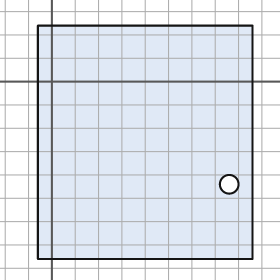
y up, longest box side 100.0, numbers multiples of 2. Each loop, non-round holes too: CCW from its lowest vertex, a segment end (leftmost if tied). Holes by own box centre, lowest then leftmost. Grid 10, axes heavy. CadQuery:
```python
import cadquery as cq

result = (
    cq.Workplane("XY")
    .moveTo(-6.0, -76.0)
    .lineTo(86.0, -76.0)
    .lineTo(86.0, 24.0)
    .lineTo(-6.0, 24.0)
    .close()
    .moveTo(76.0, -44.0)
    .circle(4.0)
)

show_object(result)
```